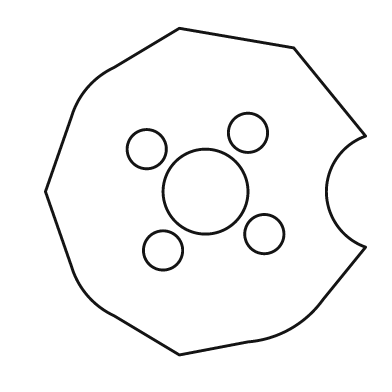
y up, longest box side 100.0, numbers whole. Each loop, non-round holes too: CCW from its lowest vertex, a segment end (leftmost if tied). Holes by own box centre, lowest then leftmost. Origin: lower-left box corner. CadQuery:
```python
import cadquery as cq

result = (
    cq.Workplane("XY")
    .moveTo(41.0, 0.0)
    .lineTo(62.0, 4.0)
    .threePointArc((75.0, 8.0), (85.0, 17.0))
    .lineTo(98.0, 33.0)
    .threePointArc((86.0, 50.0), (98.0, 67.0))
    .lineTo(76.0, 94.0)
    .lineTo(41.0, 100.0)
    .lineTo(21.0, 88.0)
    .threePointArc((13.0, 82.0), (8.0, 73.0))
    .lineTo(0.0, 50.0)
    .lineTo(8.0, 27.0)
    .threePointArc((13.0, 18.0), (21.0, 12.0))
    .close()
    .moveTo(36.0, 32.0)
    .circle(6.0)
    .moveTo(67.0, 37.0)
    .circle(6.0)
    .moveTo(49.0, 50.0)
    .circle(13.0)
    .moveTo(31.0, 63.0)
    .circle(6.0)
    .moveTo(62.0, 68.0)
    .circle(6.0)
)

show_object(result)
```